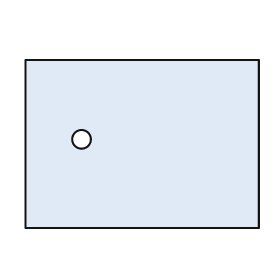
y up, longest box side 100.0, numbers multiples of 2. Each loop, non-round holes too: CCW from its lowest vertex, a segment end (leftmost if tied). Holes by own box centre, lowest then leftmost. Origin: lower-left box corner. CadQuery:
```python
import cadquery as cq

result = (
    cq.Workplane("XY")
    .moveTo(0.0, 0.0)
    .lineTo(100.0, 0.0)
    .lineTo(100.0, 72.0)
    .lineTo(0.0, 72.0)
    .close()
    .moveTo(24.0, 38.0)
    .circle(4.0)
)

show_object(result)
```